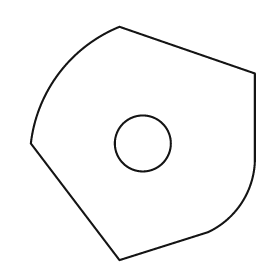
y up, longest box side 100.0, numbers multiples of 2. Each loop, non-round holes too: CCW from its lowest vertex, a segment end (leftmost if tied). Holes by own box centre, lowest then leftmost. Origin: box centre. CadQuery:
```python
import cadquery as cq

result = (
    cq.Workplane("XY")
    .moveTo(-10.0, -50.0)
    .lineTo(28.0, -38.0)
    .threePointArc((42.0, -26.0), (48.0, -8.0))
    .lineTo(48.0, 30.0)
    .lineTo(-10.0, 50.0)
    .threePointArc((-36.0, 30.0), (-48.0, 0.0))
    .close()
    .moveTo(0.0, 0.0)
    .circle(12.0)
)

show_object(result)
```